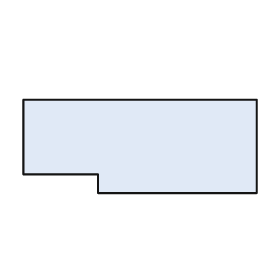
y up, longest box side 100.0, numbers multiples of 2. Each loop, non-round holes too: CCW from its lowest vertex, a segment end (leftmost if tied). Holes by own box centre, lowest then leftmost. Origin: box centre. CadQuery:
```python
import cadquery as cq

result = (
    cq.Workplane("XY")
    .moveTo(-18.0, -20.0)
    .lineTo(50.0, -20.0)
    .lineTo(50.0, 20.0)
    .lineTo(-50.0, 20.0)
    .lineTo(-50.0, -12.0)
    .lineTo(-18.0, -12.0)
    .close()
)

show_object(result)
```